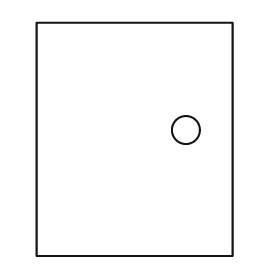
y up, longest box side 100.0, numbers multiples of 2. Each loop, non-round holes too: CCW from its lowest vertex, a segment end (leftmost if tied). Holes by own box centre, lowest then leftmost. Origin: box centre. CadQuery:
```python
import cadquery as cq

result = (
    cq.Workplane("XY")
    .moveTo(-42.0, -50.0)
    .lineTo(42.0, -50.0)
    .lineTo(42.0, 50.0)
    .lineTo(-42.0, 50.0)
    .close()
    .moveTo(22.0, 4.0)
    .circle(6.0)
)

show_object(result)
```